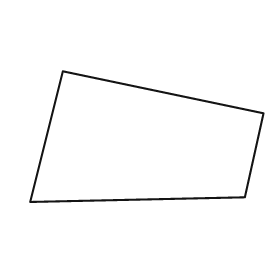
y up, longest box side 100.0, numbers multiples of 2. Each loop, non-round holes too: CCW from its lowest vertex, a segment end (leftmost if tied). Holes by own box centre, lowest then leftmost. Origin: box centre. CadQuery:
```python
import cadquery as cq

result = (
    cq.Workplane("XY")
    .moveTo(-50.0, -28.0)
    .lineTo(42.0, -26.0)
    .lineTo(50.0, 10.0)
    .lineTo(-36.0, 28.0)
    .close()
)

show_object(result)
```